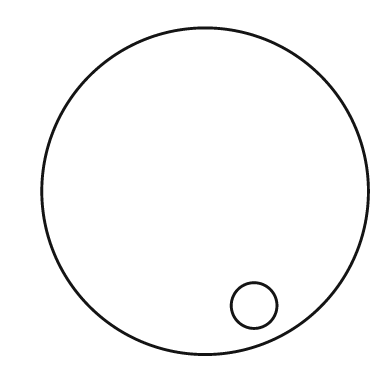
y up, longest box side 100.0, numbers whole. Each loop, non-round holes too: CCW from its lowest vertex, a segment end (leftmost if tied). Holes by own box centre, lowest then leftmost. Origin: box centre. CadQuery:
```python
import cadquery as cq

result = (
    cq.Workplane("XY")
    .moveTo(0.0, 0.0)
    .circle(50.0)
    .moveTo(15.0, -35.0)
    .circle(7.0)
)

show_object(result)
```